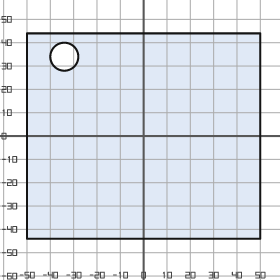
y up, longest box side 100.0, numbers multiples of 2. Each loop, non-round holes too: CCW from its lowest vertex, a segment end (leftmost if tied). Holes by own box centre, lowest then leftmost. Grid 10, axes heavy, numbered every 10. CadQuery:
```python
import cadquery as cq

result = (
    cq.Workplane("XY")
    .moveTo(-50.0, -44.0)
    .lineTo(50.0, -44.0)
    .lineTo(50.0, 44.0)
    .lineTo(-50.0, 44.0)
    .close()
    .moveTo(-34.0, 34.0)
    .circle(6.0)
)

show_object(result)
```